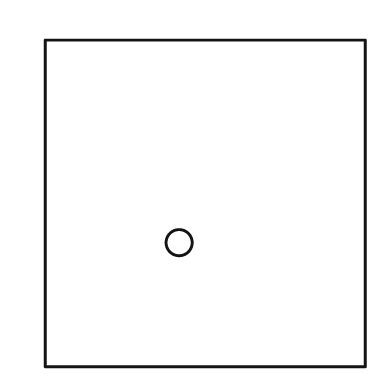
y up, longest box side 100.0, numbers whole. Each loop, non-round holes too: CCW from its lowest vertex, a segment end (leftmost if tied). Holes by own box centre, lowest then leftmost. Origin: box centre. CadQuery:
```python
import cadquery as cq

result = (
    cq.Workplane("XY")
    .moveTo(-49.0, -50.0)
    .lineTo(49.0, -50.0)
    .lineTo(49.0, 50.0)
    .lineTo(-49.0, 50.0)
    .close()
    .moveTo(-8.0, -12.0)
    .circle(4.0)
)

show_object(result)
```